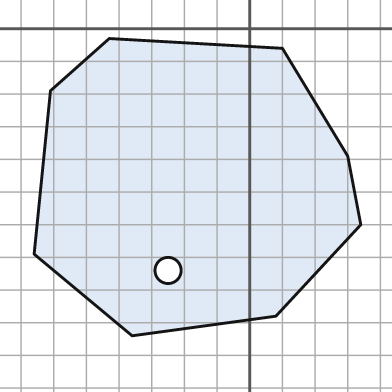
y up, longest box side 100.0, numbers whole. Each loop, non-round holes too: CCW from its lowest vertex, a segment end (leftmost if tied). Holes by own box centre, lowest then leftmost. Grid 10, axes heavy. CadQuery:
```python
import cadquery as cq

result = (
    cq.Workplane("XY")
    .moveTo(-36.0, -94.0)
    .lineTo(8.0, -88.0)
    .lineTo(34.0, -60.0)
    .lineTo(30.0, -39.0)
    .lineTo(10.0, -6.0)
    .lineTo(-43.0, -3.0)
    .lineTo(-61.0, -19.0)
    .lineTo(-66.0, -69.0)
    .close()
    .moveTo(-25.0, -74.0)
    .circle(4.0)
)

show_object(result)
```